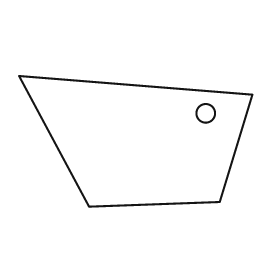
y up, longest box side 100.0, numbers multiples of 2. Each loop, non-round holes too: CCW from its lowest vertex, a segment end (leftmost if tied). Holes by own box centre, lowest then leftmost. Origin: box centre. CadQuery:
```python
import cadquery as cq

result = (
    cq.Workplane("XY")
    .moveTo(-20.0, -28.0)
    .lineTo(36.0, -26.0)
    .lineTo(50.0, 20.0)
    .lineTo(-50.0, 28.0)
    .close()
    .moveTo(30.0, 12.0)
    .circle(4.0)
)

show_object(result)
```